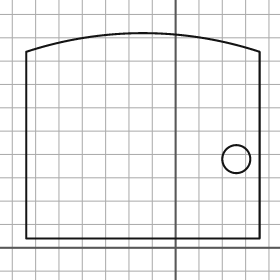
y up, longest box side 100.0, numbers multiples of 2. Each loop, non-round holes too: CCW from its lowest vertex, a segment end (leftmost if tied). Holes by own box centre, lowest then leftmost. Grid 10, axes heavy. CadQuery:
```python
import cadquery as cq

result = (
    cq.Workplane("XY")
    .moveTo(-64.0, 4.0)
    .lineTo(36.0, 4.0)
    .lineTo(36.0, 84.0)
    .threePointArc((-14.0, 92.0), (-64.0, 84.0))
    .close()
    .moveTo(26.0, 38.0)
    .circle(6.0)
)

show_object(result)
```